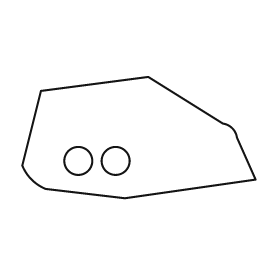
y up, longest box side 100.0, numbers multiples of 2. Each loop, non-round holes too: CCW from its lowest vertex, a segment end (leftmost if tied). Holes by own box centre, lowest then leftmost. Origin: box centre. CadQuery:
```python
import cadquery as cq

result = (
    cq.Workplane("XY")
    .moveTo(-6.0, -26.0)
    .lineTo(50.0, -18.0)
    .lineTo(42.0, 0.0)
    .threePointArc((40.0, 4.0), (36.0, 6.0))
    .lineTo(4.0, 26.0)
    .lineTo(-42.0, 20.0)
    .lineTo(-50.0, -12.0)
    .threePointArc((-46.0, -18.0), (-40.0, -22.0))
    .close()
    .moveTo(-26.0, -10.0)
    .circle(6.0)
    .moveTo(-10.0, -10.0)
    .circle(6.0)
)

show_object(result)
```